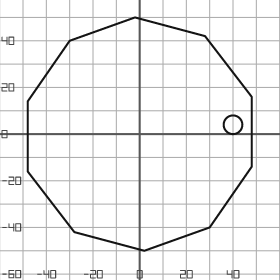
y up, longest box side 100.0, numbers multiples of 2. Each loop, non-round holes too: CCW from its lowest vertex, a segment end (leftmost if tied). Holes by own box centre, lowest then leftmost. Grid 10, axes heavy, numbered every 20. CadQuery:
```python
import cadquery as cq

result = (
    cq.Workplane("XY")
    .moveTo(2.0, -50.0)
    .lineTo(30.0, -40.0)
    .lineTo(48.0, -14.0)
    .lineTo(48.0, 16.0)
    .lineTo(28.0, 42.0)
    .lineTo(-2.0, 50.0)
    .lineTo(-30.0, 40.0)
    .lineTo(-48.0, 14.0)
    .lineTo(-48.0, -16.0)
    .lineTo(-28.0, -42.0)
    .close()
    .moveTo(40.0, 4.0)
    .circle(4.0)
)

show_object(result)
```